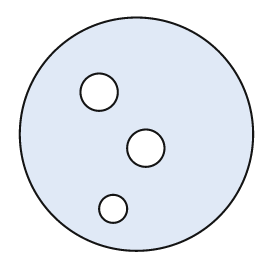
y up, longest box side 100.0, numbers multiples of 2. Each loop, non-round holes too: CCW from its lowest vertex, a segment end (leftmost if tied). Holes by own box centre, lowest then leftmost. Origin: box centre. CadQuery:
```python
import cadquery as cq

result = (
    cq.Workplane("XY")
    .moveTo(0.0, 0.0)
    .circle(50.0)
    .moveTo(-10.0, -32.0)
    .circle(6.0)
    .moveTo(4.0, -6.0)
    .circle(8.0)
    .moveTo(-16.0, 18.0)
    .circle(8.0)
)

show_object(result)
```